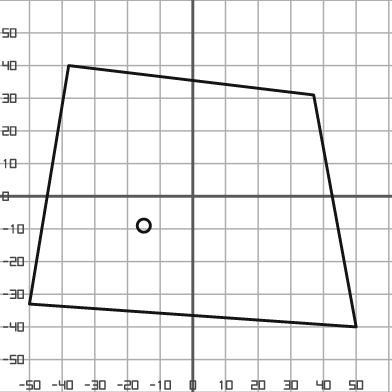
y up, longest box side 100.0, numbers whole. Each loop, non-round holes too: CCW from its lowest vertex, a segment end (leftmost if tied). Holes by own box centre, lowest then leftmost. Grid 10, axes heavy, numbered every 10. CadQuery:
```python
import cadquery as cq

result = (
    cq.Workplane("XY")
    .moveTo(50.0, -40.0)
    .lineTo(37.0, 31.0)
    .lineTo(-38.0, 40.0)
    .lineTo(-50.0, -33.0)
    .close()
    .moveTo(-15.0, -9.0)
    .circle(2.0)
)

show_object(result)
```